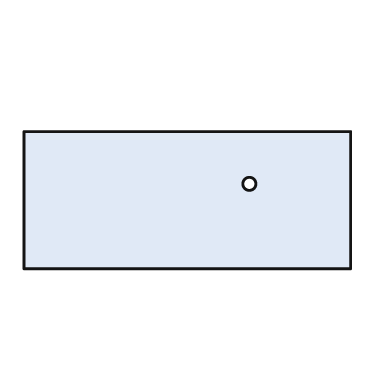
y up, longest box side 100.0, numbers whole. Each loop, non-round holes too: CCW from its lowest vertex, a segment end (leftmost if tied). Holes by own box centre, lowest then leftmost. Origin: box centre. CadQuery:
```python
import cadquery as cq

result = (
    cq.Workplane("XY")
    .moveTo(-50.0, -21.0)
    .lineTo(50.0, -21.0)
    .lineTo(50.0, 21.0)
    .lineTo(-50.0, 21.0)
    .close()
    .moveTo(19.0, 5.0)
    .circle(2.0)
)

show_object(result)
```